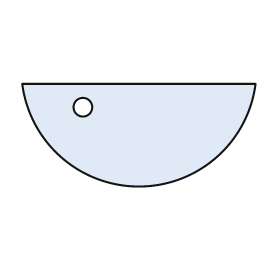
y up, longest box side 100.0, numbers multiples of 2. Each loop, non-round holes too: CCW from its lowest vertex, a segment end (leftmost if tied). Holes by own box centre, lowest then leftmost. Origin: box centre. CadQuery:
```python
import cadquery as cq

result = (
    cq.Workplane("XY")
    .moveTo(-50.0, 22.0)
    .threePointArc((0.0, -22.0), (50.0, 22.0))
    .close()
    .moveTo(-24.0, 12.0)
    .circle(4.0)
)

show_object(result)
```